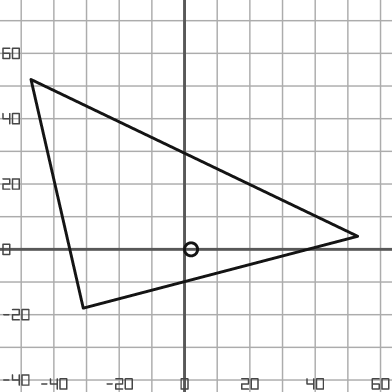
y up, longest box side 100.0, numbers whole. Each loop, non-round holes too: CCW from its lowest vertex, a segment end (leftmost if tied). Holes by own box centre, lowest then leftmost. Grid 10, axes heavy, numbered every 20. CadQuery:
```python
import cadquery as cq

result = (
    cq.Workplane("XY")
    .moveTo(-31.0, -18.0)
    .lineTo(53.0, 4.0)
    .lineTo(-47.0, 52.0)
    .close()
    .moveTo(2.0, 0.0)
    .circle(2.0)
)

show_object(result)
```